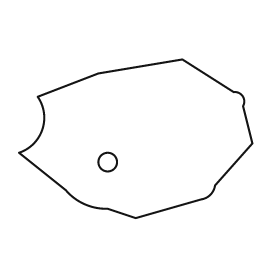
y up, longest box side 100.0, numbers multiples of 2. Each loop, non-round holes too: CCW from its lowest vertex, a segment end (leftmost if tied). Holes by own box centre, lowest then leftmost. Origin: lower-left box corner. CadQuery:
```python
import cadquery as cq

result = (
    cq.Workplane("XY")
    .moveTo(50.0, 0.0)
    .lineTo(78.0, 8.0)
    .threePointArc((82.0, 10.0), (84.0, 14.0))
    .lineTo(100.0, 32.0)
    .lineTo(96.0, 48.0)
    .threePointArc((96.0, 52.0), (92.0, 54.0))
    .lineTo(70.0, 68.0)
    .lineTo(34.0, 62.0)
    .lineTo(8.0, 52.0)
    .threePointArc((10.0, 38.0), (0.0, 28.0))
    .lineTo(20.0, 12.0)
    .threePointArc((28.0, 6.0), (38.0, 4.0))
    .close()
    .moveTo(38.0, 24.0)
    .circle(4.0)
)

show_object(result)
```